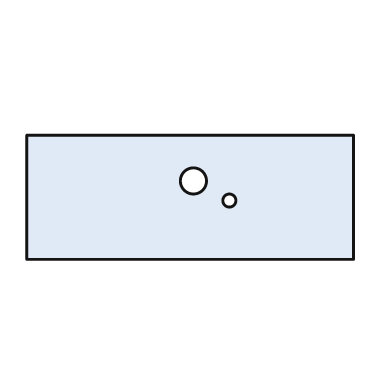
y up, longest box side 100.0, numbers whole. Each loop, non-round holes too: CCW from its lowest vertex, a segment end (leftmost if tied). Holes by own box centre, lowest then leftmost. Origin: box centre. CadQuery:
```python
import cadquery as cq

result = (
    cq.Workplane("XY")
    .moveTo(-50.0, -19.0)
    .lineTo(50.0, -19.0)
    .lineTo(50.0, 19.0)
    .lineTo(-50.0, 19.0)
    .close()
    .moveTo(12.0, -1.0)
    .circle(2.0)
    .moveTo(1.0, 5.0)
    .circle(4.0)
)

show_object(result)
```